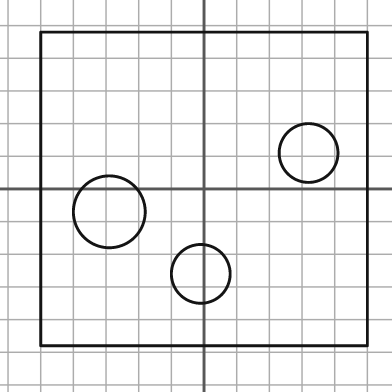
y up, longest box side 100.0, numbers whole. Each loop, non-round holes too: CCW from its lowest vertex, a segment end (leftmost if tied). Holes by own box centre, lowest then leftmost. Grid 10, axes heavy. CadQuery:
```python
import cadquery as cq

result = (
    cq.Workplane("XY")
    .moveTo(-50.0, -48.0)
    .lineTo(50.0, -48.0)
    .lineTo(50.0, 48.0)
    .lineTo(-50.0, 48.0)
    .close()
    .moveTo(-1.0, -26.0)
    .circle(9.0)
    .moveTo(-29.0, -7.0)
    .circle(11.0)
    .moveTo(32.0, 11.0)
    .circle(9.0)
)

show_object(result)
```